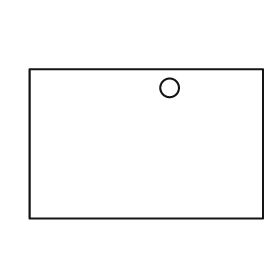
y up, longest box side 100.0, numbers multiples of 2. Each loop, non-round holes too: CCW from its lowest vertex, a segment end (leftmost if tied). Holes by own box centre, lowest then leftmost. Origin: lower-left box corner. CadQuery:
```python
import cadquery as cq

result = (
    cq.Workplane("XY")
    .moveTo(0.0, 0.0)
    .lineTo(100.0, 0.0)
    .lineTo(100.0, 64.0)
    .lineTo(0.0, 64.0)
    .close()
    .moveTo(60.0, 56.0)
    .circle(4.0)
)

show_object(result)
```